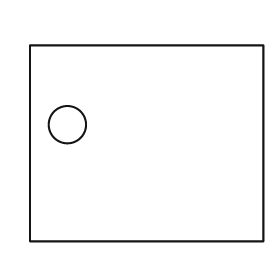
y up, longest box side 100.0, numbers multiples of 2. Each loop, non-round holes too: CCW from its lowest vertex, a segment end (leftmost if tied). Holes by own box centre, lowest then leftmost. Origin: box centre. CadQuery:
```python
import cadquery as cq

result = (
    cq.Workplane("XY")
    .moveTo(-50.0, -42.0)
    .lineTo(50.0, -42.0)
    .lineTo(50.0, 42.0)
    .lineTo(-50.0, 42.0)
    .close()
    .moveTo(-34.0, 8.0)
    .circle(8.0)
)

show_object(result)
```